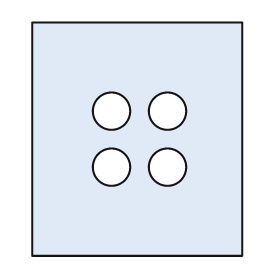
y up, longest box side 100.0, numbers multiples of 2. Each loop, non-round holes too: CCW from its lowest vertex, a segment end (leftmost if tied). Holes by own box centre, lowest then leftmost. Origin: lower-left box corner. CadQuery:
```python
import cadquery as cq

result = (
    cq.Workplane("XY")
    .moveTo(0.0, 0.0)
    .lineTo(90.0, 0.0)
    .lineTo(90.0, 100.0)
    .lineTo(0.0, 100.0)
    .close()
    .moveTo(34.0, 38.0)
    .circle(8.0)
    .moveTo(58.0, 38.0)
    .circle(8.0)
    .moveTo(34.0, 62.0)
    .circle(8.0)
    .moveTo(58.0, 62.0)
    .circle(8.0)
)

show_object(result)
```